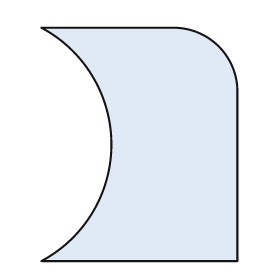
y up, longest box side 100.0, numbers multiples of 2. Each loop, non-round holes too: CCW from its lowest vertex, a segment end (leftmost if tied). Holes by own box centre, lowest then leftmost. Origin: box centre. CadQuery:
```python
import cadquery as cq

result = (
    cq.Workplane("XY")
    .moveTo(-42.0, -50.0)
    .lineTo(42.0, -50.0)
    .lineTo(42.0, 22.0)
    .threePointArc((34.0, 42.0), (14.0, 50.0))
    .lineTo(-42.0, 50.0)
    .threePointArc((-12.0, 0.0), (-42.0, -50.0))
    .close()
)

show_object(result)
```